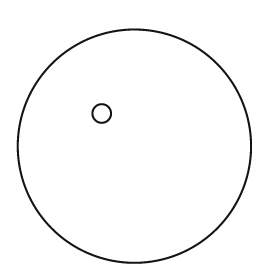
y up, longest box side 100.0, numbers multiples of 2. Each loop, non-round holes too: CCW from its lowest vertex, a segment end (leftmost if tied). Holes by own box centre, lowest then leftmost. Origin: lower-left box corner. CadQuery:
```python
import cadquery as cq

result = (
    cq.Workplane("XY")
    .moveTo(50.0, 50.0)
    .circle(50.0)
    .moveTo(36.0, 64.0)
    .circle(4.0)
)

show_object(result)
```